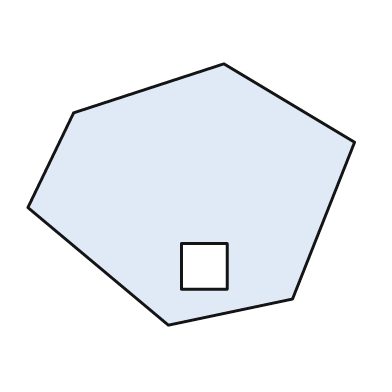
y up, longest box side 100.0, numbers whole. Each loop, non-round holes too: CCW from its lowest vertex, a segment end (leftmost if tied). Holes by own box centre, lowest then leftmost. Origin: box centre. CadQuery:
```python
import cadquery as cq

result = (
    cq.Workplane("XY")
    .moveTo(-7.0, -40.0)
    .lineTo(31.0, -32.0)
    .lineTo(50.0, 16.0)
    .lineTo(10.0, 40.0)
    .lineTo(-36.0, 25.0)
    .lineTo(-50.0, -4.0)
    .close()
    .moveTo(-3.0, -29.0)
    .lineTo(11.0, -29.0)
    .lineTo(11.0, -15.0)
    .lineTo(-3.0, -15.0)
    .close()
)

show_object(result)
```